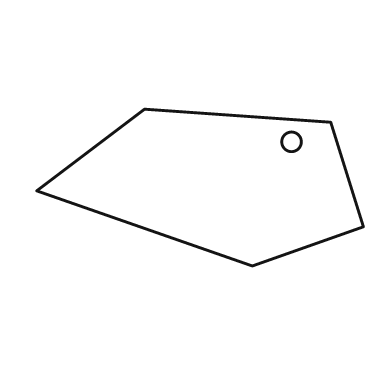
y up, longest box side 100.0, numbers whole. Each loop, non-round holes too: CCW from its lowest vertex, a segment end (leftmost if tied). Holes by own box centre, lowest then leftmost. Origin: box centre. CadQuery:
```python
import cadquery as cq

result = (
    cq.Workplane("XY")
    .moveTo(16.0, -24.0)
    .lineTo(50.0, -12.0)
    .lineTo(40.0, 20.0)
    .lineTo(-17.0, 24.0)
    .lineTo(-50.0, -1.0)
    .close()
    .moveTo(28.0, 14.0)
    .circle(3.0)
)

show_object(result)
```